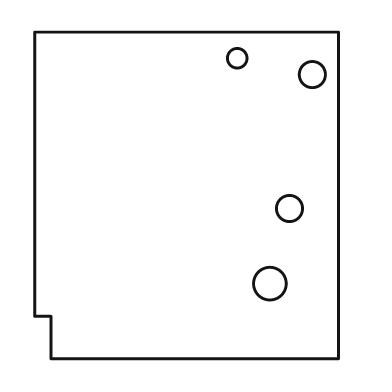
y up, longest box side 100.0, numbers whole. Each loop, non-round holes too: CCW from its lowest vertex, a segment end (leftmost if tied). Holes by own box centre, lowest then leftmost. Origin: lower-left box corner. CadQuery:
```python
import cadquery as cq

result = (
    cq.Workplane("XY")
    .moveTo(5.0, 0.0)
    .lineTo(93.0, 0.0)
    .lineTo(93.0, 100.0)
    .lineTo(0.0, 100.0)
    .lineTo(0.0, 13.0)
    .lineTo(5.0, 13.0)
    .close()
    .moveTo(72.0, 23.0)
    .circle(5.0)
    .moveTo(78.0, 46.0)
    .circle(4.0)
    .moveTo(85.0, 87.0)
    .circle(4.0)
    .moveTo(62.0, 92.0)
    .circle(3.0)
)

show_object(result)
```